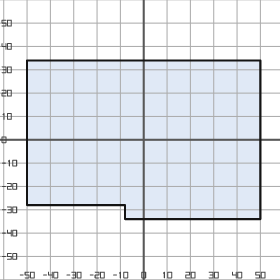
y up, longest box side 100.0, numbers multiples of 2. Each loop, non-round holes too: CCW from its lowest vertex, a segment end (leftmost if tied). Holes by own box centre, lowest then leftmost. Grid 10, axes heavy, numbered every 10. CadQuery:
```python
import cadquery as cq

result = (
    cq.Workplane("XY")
    .moveTo(-8.0, -34.0)
    .lineTo(50.0, -34.0)
    .lineTo(50.0, 34.0)
    .lineTo(-50.0, 34.0)
    .lineTo(-50.0, -28.0)
    .lineTo(-8.0, -28.0)
    .close()
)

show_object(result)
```